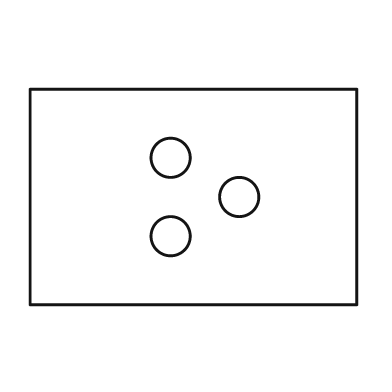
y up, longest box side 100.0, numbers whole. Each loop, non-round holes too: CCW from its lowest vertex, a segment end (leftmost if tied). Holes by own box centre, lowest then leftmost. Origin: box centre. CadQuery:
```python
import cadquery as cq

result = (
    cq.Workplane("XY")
    .moveTo(-50.0, -33.0)
    .lineTo(50.0, -33.0)
    .lineTo(50.0, 33.0)
    .lineTo(-50.0, 33.0)
    .close()
    .moveTo(-7.0, -12.0)
    .circle(6.0)
    .moveTo(14.0, 0.0)
    .circle(6.0)
    .moveTo(-7.0, 12.0)
    .circle(6.0)
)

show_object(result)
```